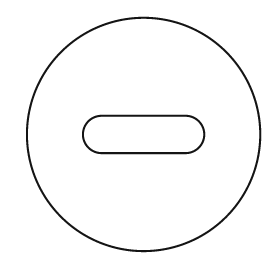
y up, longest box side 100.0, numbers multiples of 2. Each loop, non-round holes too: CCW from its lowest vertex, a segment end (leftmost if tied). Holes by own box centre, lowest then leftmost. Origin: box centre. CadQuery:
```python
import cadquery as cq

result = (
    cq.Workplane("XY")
    .moveTo(0.0, 0.0)
    .circle(50.0)
    .moveTo(-18.0, -8.0)
    .lineTo(18.0, -8.0)
    .threePointArc((26.0, 0.0), (18.0, 8.0))
    .lineTo(-18.0, 8.0)
    .threePointArc((-26.0, 0.0), (-18.0, -8.0))
    .close()
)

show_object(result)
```